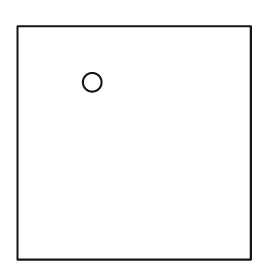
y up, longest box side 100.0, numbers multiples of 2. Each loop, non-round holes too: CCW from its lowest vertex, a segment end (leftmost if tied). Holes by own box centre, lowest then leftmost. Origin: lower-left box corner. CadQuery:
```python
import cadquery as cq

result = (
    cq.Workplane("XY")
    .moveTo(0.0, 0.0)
    .lineTo(100.0, 0.0)
    .lineTo(100.0, 100.0)
    .lineTo(0.0, 100.0)
    .close()
    .moveTo(32.0, 76.0)
    .circle(4.0)
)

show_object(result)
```